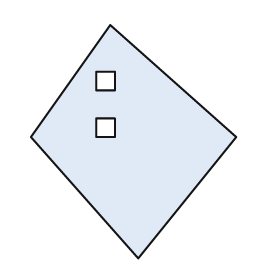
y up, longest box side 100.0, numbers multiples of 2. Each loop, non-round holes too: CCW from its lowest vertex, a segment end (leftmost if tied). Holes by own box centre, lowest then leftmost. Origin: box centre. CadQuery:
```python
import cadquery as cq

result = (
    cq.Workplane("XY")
    .moveTo(2.0, -50.0)
    .lineTo(44.0, 2.0)
    .lineTo(-10.0, 50.0)
    .lineTo(-44.0, 2.0)
    .close()
    .moveTo(-16.0, 2.0)
    .lineTo(-8.0, 2.0)
    .lineTo(-8.0, 10.0)
    .lineTo(-16.0, 10.0)
    .close()
    .moveTo(-16.0, 22.0)
    .lineTo(-8.0, 22.0)
    .lineTo(-8.0, 30.0)
    .lineTo(-16.0, 30.0)
    .close()
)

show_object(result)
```